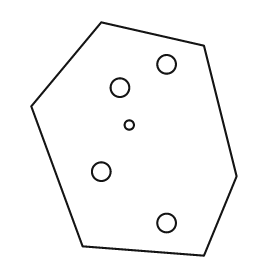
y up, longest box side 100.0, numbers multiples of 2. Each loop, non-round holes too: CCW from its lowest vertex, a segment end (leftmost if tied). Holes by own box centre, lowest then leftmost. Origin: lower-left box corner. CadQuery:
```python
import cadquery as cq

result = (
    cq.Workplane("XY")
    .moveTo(74.0, 0.0)
    .lineTo(88.0, 34.0)
    .lineTo(74.0, 90.0)
    .lineTo(30.0, 100.0)
    .lineTo(0.0, 64.0)
    .lineTo(22.0, 4.0)
    .close()
    .moveTo(58.0, 14.0)
    .circle(4.0)
    .moveTo(30.0, 36.0)
    .circle(4.0)
    .moveTo(42.0, 56.0)
    .circle(2.0)
    .moveTo(38.0, 72.0)
    .circle(4.0)
    .moveTo(58.0, 82.0)
    .circle(4.0)
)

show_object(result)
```